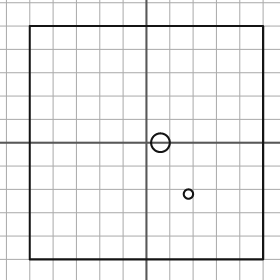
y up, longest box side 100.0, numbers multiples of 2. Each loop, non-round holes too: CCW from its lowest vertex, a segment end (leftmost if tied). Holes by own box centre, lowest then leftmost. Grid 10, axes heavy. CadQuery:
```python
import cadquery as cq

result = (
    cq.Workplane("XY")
    .moveTo(-50.0, -50.0)
    .lineTo(50.0, -50.0)
    .lineTo(50.0, 50.0)
    .lineTo(-50.0, 50.0)
    .close()
    .moveTo(18.0, -22.0)
    .circle(2.0)
    .moveTo(6.0, 0.0)
    .circle(4.0)
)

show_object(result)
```